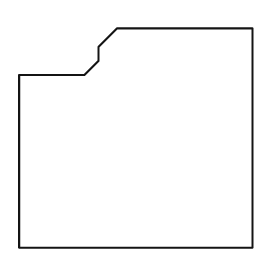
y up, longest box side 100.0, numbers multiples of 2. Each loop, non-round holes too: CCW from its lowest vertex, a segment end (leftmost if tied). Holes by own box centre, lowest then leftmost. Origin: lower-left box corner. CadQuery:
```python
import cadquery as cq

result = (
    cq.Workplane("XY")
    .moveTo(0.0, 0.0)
    .lineTo(100.0, 0.0)
    .lineTo(100.0, 94.0)
    .lineTo(42.0, 94.0)
    .lineTo(34.0, 86.0)
    .lineTo(34.0, 80.0)
    .lineTo(28.0, 74.0)
    .lineTo(0.0, 74.0)
    .close()
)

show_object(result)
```